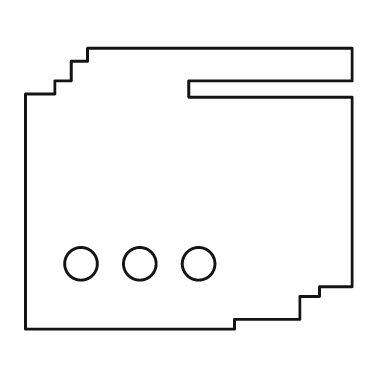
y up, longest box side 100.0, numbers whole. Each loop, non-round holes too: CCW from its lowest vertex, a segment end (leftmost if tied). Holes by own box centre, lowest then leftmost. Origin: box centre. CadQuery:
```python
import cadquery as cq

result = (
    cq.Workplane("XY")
    .moveTo(-50.0, -43.0)
    .lineTo(14.0, -43.0)
    .lineTo(14.0, -40.0)
    .lineTo(34.0, -40.0)
    .lineTo(34.0, -33.0)
    .lineTo(40.0, -33.0)
    .lineTo(40.0, -30.0)
    .lineTo(50.0, -30.0)
    .lineTo(50.0, 28.0)
    .lineTo(0.0, 28.0)
    .lineTo(0.0, 33.0)
    .lineTo(50.0, 33.0)
    .lineTo(50.0, 43.0)
    .lineTo(-31.0, 43.0)
    .lineTo(-31.0, 39.0)
    .lineTo(-36.0, 39.0)
    .lineTo(-36.0, 33.0)
    .lineTo(-41.0, 33.0)
    .lineTo(-41.0, 29.0)
    .lineTo(-50.0, 29.0)
    .close()
    .moveTo(-33.0, -23.0)
    .circle(5.0)
    .moveTo(-15.0, -23.0)
    .circle(5.0)
    .moveTo(3.0, -23.0)
    .circle(5.0)
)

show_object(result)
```